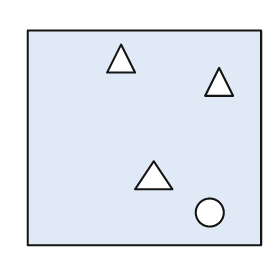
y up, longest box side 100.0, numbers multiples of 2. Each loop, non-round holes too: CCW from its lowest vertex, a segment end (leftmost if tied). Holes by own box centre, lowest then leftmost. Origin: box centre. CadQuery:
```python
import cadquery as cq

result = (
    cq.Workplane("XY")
    .moveTo(-50.0, -46.0)
    .lineTo(50.0, -46.0)
    .lineTo(50.0, 46.0)
    .lineTo(-50.0, 46.0)
    .close()
    .moveTo(28.0, -32.0)
    .circle(6.0)
    .moveTo(-4.0, -22.0)
    .lineTo(12.0, -22.0)
    .lineTo(4.0, -10.0)
    .close()
    .moveTo(26.0, 18.0)
    .lineTo(38.0, 18.0)
    .lineTo(32.0, 30.0)
    .close()
    .moveTo(-16.0, 28.0)
    .lineTo(-4.0, 28.0)
    .lineTo(-10.0, 40.0)
    .close()
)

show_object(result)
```